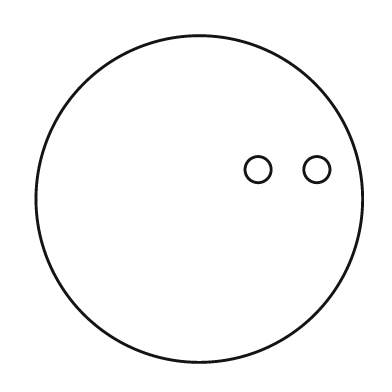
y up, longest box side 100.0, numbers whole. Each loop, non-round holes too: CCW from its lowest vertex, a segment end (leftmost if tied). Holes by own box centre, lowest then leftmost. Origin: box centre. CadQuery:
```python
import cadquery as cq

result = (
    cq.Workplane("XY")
    .moveTo(0.0, 0.0)
    .circle(50.0)
    .moveTo(18.0, 9.0)
    .circle(4.0)
    .moveTo(36.0, 9.0)
    .circle(4.0)
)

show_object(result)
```